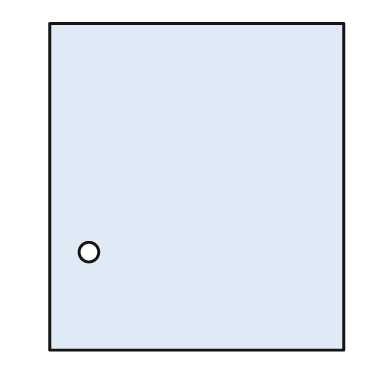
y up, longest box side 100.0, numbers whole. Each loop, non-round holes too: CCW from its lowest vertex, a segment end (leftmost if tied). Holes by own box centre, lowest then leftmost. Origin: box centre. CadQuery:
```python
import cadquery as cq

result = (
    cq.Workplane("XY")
    .moveTo(-45.0, -50.0)
    .lineTo(45.0, -50.0)
    .lineTo(45.0, 50.0)
    .lineTo(-45.0, 50.0)
    .close()
    .moveTo(-33.0, -20.0)
    .circle(3.0)
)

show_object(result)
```